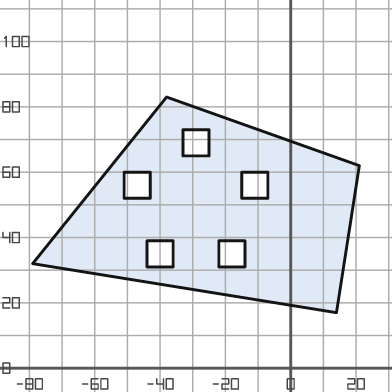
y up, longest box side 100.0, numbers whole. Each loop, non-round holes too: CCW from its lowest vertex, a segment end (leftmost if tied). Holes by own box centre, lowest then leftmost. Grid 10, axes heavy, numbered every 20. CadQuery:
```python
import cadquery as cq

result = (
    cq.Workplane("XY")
    .moveTo(14.0, 17.0)
    .lineTo(21.0, 62.0)
    .lineTo(-38.0, 83.0)
    .lineTo(-79.0, 32.0)
    .close()
    .moveTo(-44.0, 31.0)
    .lineTo(-36.0, 31.0)
    .lineTo(-36.0, 39.0)
    .lineTo(-44.0, 39.0)
    .close()
    .moveTo(-22.0, 31.0)
    .lineTo(-14.0, 31.0)
    .lineTo(-14.0, 39.0)
    .lineTo(-22.0, 39.0)
    .close()
    .moveTo(-51.0, 52.0)
    .lineTo(-43.0, 52.0)
    .lineTo(-43.0, 60.0)
    .lineTo(-51.0, 60.0)
    .close()
    .moveTo(-15.0, 52.0)
    .lineTo(-7.0, 52.0)
    .lineTo(-7.0, 60.0)
    .lineTo(-15.0, 60.0)
    .close()
    .moveTo(-33.0, 65.0)
    .lineTo(-25.0, 65.0)
    .lineTo(-25.0, 73.0)
    .lineTo(-33.0, 73.0)
    .close()
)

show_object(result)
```